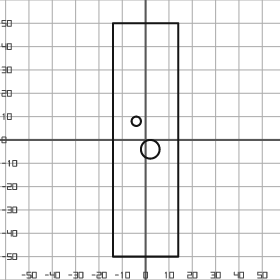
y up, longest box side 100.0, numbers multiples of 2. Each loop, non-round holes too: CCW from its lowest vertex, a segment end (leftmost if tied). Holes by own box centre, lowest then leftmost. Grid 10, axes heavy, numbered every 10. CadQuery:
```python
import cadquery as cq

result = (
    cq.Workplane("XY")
    .moveTo(-14.0, -50.0)
    .lineTo(14.0, -50.0)
    .lineTo(14.0, 50.0)
    .lineTo(-14.0, 50.0)
    .close()
    .moveTo(2.0, -4.0)
    .circle(4.0)
    .moveTo(-4.0, 8.0)
    .circle(2.0)
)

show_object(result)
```